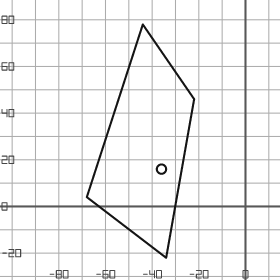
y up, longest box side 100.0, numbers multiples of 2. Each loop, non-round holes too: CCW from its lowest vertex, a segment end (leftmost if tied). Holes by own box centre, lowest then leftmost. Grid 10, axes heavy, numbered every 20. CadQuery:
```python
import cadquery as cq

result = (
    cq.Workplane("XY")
    .moveTo(-34.0, -22.0)
    .lineTo(-22.0, 46.0)
    .lineTo(-44.0, 78.0)
    .lineTo(-68.0, 4.0)
    .close()
    .moveTo(-36.0, 16.0)
    .circle(2.0)
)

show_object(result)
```